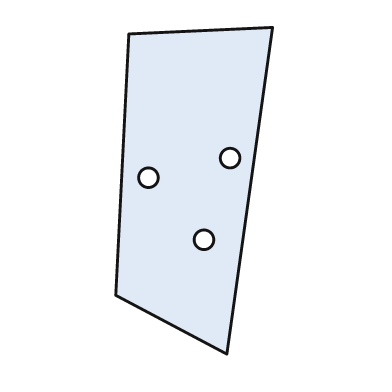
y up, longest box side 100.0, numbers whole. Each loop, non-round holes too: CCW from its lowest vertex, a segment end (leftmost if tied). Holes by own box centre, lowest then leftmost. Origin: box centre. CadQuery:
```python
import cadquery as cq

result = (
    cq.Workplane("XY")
    .moveTo(10.0, -50.0)
    .lineTo(24.0, 50.0)
    .lineTo(-20.0, 48.0)
    .lineTo(-24.0, -32.0)
    .close()
    .moveTo(3.0, -15.0)
    .circle(3.0)
    .moveTo(-14.0, 4.0)
    .circle(3.0)
    .moveTo(11.0, 10.0)
    .circle(3.0)
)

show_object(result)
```